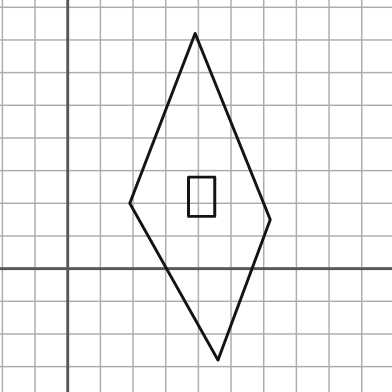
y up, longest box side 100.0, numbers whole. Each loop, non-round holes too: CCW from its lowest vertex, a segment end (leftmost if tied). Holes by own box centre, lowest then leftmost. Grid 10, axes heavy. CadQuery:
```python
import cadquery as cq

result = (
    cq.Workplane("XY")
    .moveTo(46.0, -28.0)
    .lineTo(62.0, 15.0)
    .lineTo(39.0, 72.0)
    .lineTo(19.0, 20.0)
    .close()
    .moveTo(37.0, 16.0)
    .lineTo(45.0, 16.0)
    .lineTo(45.0, 28.0)
    .lineTo(37.0, 28.0)
    .close()
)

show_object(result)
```